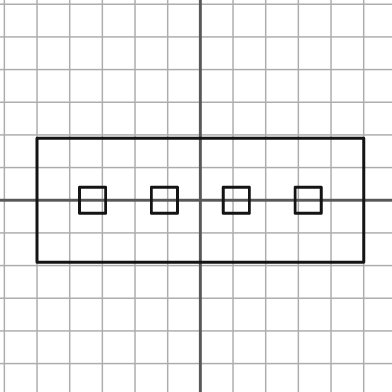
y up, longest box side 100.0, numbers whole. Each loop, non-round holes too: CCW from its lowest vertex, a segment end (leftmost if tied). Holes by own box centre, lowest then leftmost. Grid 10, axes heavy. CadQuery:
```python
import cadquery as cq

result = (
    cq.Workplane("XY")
    .moveTo(-50.0, -19.0)
    .lineTo(50.0, -19.0)
    .lineTo(50.0, 19.0)
    .lineTo(-50.0, 19.0)
    .close()
    .moveTo(-37.0, -4.0)
    .lineTo(-29.0, -4.0)
    .lineTo(-29.0, 4.0)
    .lineTo(-37.0, 4.0)
    .close()
    .moveTo(-15.0, -4.0)
    .lineTo(-7.0, -4.0)
    .lineTo(-7.0, 4.0)
    .lineTo(-15.0, 4.0)
    .close()
    .moveTo(7.0, -4.0)
    .lineTo(15.0, -4.0)
    .lineTo(15.0, 4.0)
    .lineTo(7.0, 4.0)
    .close()
    .moveTo(29.0, -4.0)
    .lineTo(37.0, -4.0)
    .lineTo(37.0, 4.0)
    .lineTo(29.0, 4.0)
    .close()
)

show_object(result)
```